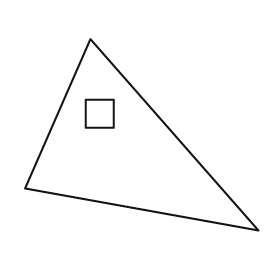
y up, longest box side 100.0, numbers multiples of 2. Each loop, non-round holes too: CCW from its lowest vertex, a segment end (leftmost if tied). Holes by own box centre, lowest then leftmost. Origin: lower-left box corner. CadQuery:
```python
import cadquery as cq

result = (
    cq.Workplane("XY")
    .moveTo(100.0, 0.0)
    .lineTo(28.0, 82.0)
    .lineTo(0.0, 18.0)
    .close()
    .moveTo(26.0, 44.0)
    .lineTo(38.0, 44.0)
    .lineTo(38.0, 56.0)
    .lineTo(26.0, 56.0)
    .close()
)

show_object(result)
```